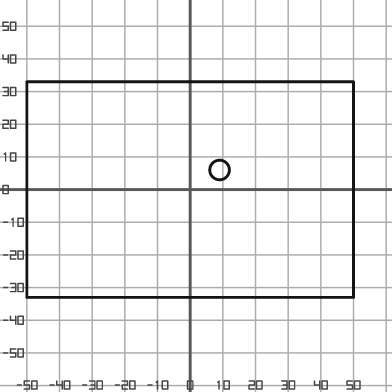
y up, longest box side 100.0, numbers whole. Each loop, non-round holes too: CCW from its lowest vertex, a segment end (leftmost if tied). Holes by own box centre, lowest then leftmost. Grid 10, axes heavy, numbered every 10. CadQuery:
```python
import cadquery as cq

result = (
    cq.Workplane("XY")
    .moveTo(-50.0, -33.0)
    .lineTo(50.0, -33.0)
    .lineTo(50.0, 33.0)
    .lineTo(-50.0, 33.0)
    .close()
    .moveTo(9.0, 6.0)
    .circle(3.0)
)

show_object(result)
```